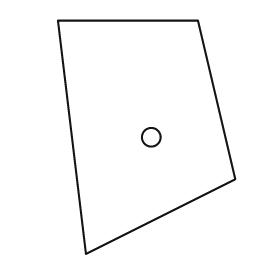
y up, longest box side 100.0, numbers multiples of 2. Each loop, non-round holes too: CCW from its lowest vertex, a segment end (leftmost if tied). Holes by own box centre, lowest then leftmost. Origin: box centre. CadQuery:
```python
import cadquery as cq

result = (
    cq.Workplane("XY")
    .moveTo(-26.0, -50.0)
    .lineTo(38.0, -18.0)
    .lineTo(22.0, 50.0)
    .lineTo(-38.0, 50.0)
    .close()
    .moveTo(2.0, 0.0)
    .circle(4.0)
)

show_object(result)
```